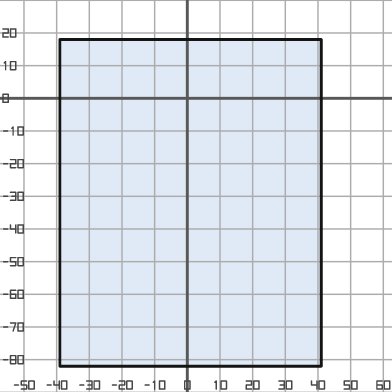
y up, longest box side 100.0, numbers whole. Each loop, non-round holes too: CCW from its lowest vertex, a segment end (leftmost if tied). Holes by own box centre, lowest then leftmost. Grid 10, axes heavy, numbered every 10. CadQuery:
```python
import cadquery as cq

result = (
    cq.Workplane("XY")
    .moveTo(-39.0, -82.0)
    .lineTo(41.0, -82.0)
    .lineTo(41.0, 18.0)
    .lineTo(-39.0, 18.0)
    .close()
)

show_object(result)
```